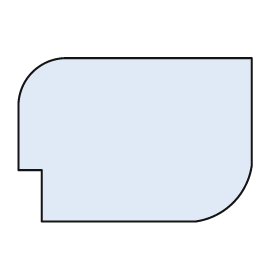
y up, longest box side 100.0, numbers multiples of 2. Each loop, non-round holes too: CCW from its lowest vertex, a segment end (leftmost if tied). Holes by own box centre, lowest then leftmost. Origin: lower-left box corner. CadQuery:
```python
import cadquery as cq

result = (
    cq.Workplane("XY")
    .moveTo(10.0, 0.0)
    .lineTo(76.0, 0.0)
    .threePointArc((92.0, 8.0), (100.0, 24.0))
    .lineTo(100.0, 70.0)
    .lineTo(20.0, 70.0)
    .threePointArc((6.0, 64.0), (0.0, 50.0))
    .lineTo(0.0, 22.0)
    .lineTo(10.0, 22.0)
    .close()
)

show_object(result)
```